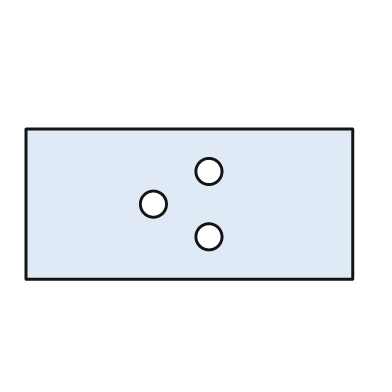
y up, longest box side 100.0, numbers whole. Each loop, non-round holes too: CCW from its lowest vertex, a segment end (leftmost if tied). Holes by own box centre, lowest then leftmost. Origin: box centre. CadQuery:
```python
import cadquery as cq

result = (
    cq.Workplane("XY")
    .moveTo(-50.0, -23.0)
    .lineTo(50.0, -23.0)
    .lineTo(50.0, 23.0)
    .lineTo(-50.0, 23.0)
    .close()
    .moveTo(6.0, -10.0)
    .circle(4.0)
    .moveTo(-11.0, 0.0)
    .circle(4.0)
    .moveTo(6.0, 10.0)
    .circle(4.0)
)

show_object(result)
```